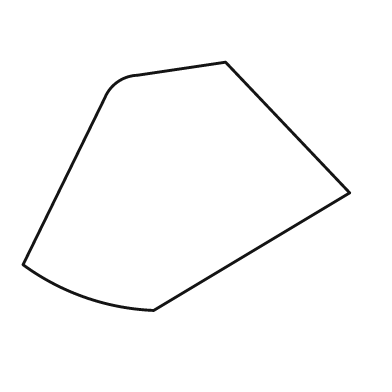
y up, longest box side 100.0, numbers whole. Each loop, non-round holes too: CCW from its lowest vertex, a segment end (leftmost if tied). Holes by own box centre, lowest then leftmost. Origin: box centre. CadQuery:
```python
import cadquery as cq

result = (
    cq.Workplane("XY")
    .moveTo(-10.0, -38.0)
    .lineTo(50.0, -2.0)
    .lineTo(12.0, 38.0)
    .lineTo(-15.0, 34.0)
    .threePointArc((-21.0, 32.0), (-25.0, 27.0))
    .lineTo(-50.0, -24.0)
    .threePointArc((-31.0, -34.0), (-10.0, -38.0))
    .close()
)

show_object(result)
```